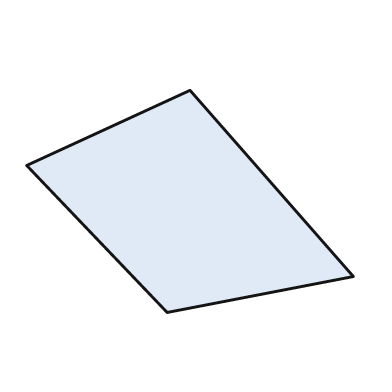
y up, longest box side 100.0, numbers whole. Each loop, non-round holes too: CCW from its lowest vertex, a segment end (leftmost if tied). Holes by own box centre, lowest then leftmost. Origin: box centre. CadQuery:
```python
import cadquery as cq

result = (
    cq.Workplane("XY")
    .moveTo(-7.0, -34.0)
    .lineTo(50.0, -23.0)
    .lineTo(0.0, 34.0)
    .lineTo(-50.0, 11.0)
    .close()
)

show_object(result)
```